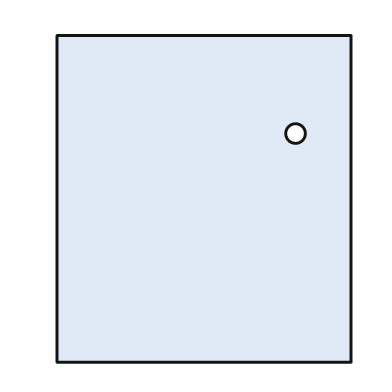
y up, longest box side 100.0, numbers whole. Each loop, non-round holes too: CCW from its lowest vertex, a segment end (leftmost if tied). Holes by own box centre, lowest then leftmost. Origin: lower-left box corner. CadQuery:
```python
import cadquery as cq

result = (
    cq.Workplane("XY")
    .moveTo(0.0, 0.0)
    .lineTo(90.0, 0.0)
    .lineTo(90.0, 100.0)
    .lineTo(0.0, 100.0)
    .close()
    .moveTo(73.0, 70.0)
    .circle(3.0)
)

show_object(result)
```